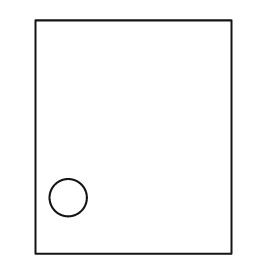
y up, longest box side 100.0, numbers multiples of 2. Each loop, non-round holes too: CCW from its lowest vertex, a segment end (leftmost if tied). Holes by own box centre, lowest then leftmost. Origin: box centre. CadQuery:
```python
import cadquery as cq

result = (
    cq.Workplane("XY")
    .moveTo(-42.0, -50.0)
    .lineTo(42.0, -50.0)
    .lineTo(42.0, 50.0)
    .lineTo(-42.0, 50.0)
    .close()
    .moveTo(-28.0, -26.0)
    .circle(8.0)
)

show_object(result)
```